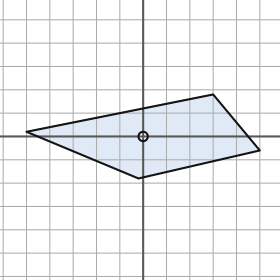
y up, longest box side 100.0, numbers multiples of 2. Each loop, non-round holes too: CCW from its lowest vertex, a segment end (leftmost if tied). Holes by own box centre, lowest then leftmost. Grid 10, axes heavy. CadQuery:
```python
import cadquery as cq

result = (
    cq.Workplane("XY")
    .moveTo(-2.0, -18.0)
    .lineTo(50.0, -6.0)
    .lineTo(30.0, 18.0)
    .lineTo(-50.0, 2.0)
    .close()
    .moveTo(0.0, 0.0)
    .circle(2.0)
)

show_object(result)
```